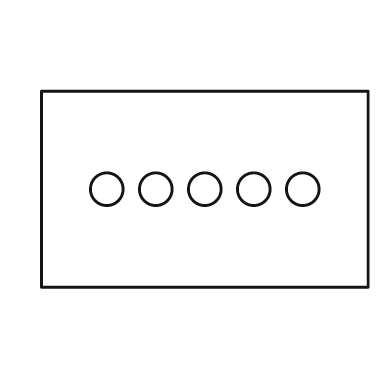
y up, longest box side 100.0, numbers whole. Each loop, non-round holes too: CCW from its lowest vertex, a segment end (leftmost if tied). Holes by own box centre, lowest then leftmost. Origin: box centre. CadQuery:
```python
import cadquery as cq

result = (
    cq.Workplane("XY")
    .moveTo(-50.0, -30.0)
    .lineTo(50.0, -30.0)
    .lineTo(50.0, 30.0)
    .lineTo(-50.0, 30.0)
    .close()
    .moveTo(-30.0, 0.0)
    .circle(5.0)
    .moveTo(-15.0, 0.0)
    .circle(5.0)
    .moveTo(0.0, 0.0)
    .circle(5.0)
    .moveTo(15.0, 0.0)
    .circle(5.0)
    .moveTo(30.0, 0.0)
    .circle(5.0)
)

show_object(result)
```